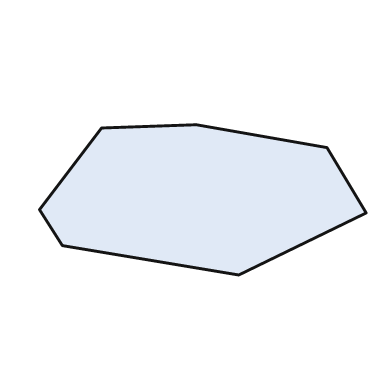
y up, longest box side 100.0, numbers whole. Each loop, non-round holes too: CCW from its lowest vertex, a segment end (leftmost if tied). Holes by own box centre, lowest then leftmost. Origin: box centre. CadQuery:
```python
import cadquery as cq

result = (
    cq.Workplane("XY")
    .moveTo(11.0, -23.0)
    .lineTo(50.0, -4.0)
    .lineTo(38.0, 16.0)
    .lineTo(-2.0, 23.0)
    .lineTo(-31.0, 22.0)
    .lineTo(-50.0, -3.0)
    .lineTo(-43.0, -14.0)
    .close()
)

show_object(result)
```